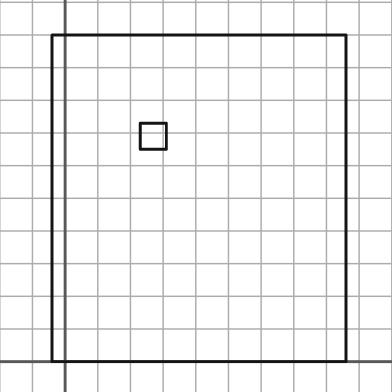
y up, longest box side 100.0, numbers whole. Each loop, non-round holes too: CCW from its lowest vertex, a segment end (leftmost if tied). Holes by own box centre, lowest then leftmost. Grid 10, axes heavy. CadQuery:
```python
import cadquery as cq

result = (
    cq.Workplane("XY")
    .moveTo(-4.0, 0.0)
    .lineTo(86.0, 0.0)
    .lineTo(86.0, 100.0)
    .lineTo(-4.0, 100.0)
    .close()
    .moveTo(23.0, 65.0)
    .lineTo(31.0, 65.0)
    .lineTo(31.0, 73.0)
    .lineTo(23.0, 73.0)
    .close()
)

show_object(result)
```